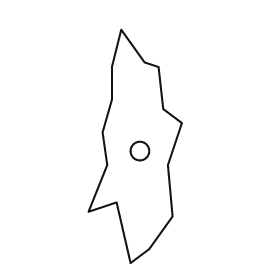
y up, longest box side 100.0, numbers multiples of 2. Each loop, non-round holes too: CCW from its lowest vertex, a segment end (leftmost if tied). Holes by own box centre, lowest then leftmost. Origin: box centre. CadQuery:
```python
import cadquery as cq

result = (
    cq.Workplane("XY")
    .moveTo(-2.0, -50.0)
    .lineTo(6.0, -44.0)
    .lineTo(16.0, -30.0)
    .lineTo(14.0, -8.0)
    .lineTo(20.0, 10.0)
    .lineTo(12.0, 16.0)
    .lineTo(10.0, 34.0)
    .lineTo(4.0, 36.0)
    .lineTo(-6.0, 50.0)
    .lineTo(-10.0, 34.0)
    .lineTo(-10.0, 20.0)
    .lineTo(-14.0, 6.0)
    .lineTo(-12.0, -8.0)
    .lineTo(-20.0, -28.0)
    .lineTo(-8.0, -24.0)
    .close()
    .moveTo(2.0, -2.0)
    .circle(4.0)
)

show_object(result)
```